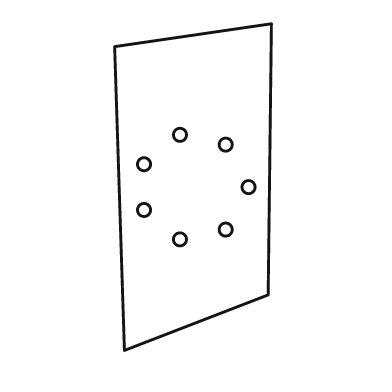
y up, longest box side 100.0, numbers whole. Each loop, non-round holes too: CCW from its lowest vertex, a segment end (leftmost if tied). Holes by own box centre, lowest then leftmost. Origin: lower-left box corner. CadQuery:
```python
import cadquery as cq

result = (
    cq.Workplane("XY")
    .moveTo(3.0, 0.0)
    .lineTo(47.0, 17.0)
    .lineTo(48.0, 100.0)
    .lineTo(0.0, 93.0)
    .close()
    .moveTo(20.0, 34.0)
    .circle(2.0)
    .moveTo(34.0, 37.0)
    .circle(2.0)
    .moveTo(9.0, 43.0)
    .circle(2.0)
    .moveTo(41.0, 50.0)
    .circle(2.0)
    .moveTo(9.0, 57.0)
    .circle(2.0)
    .moveTo(34.0, 63.0)
    .circle(2.0)
    .moveTo(20.0, 66.0)
    .circle(2.0)
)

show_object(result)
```